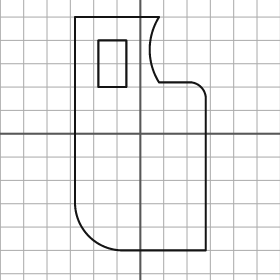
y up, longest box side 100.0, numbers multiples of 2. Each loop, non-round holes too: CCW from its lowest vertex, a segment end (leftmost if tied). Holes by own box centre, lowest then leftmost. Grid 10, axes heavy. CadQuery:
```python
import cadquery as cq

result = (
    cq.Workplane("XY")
    .moveTo(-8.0, -50.0)
    .lineTo(28.0, -50.0)
    .lineTo(28.0, 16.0)
    .threePointArc((26.0, 20.0), (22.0, 22.0))
    .lineTo(8.0, 22.0)
    .threePointArc((4.0, 36.0), (8.0, 50.0))
    .lineTo(-28.0, 50.0)
    .lineTo(-28.0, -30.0)
    .threePointArc((-22.0, -44.0), (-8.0, -50.0))
    .close()
    .moveTo(-18.0, 20.0)
    .lineTo(-6.0, 20.0)
    .lineTo(-6.0, 40.0)
    .lineTo(-18.0, 40.0)
    .close()
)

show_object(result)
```